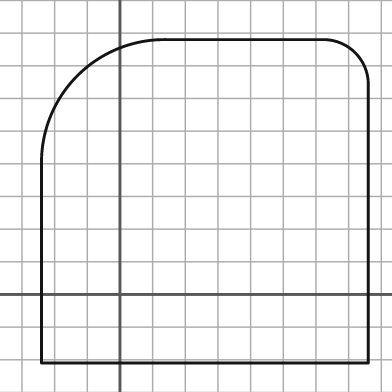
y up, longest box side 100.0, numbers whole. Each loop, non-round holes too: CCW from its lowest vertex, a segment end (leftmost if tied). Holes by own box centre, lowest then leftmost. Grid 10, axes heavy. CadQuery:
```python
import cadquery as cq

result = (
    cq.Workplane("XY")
    .moveTo(-24.0, -21.0)
    .lineTo(76.0, -21.0)
    .lineTo(76.0, 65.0)
    .threePointArc((72.0, 74.0), (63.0, 78.0))
    .lineTo(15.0, 78.0)
    .threePointArc((-13.0, 67.0), (-24.0, 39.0))
    .close()
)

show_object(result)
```